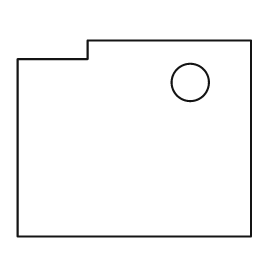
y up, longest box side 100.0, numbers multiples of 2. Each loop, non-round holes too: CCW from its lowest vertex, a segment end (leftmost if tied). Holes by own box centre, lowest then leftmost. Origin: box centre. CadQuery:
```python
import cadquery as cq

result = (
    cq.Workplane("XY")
    .moveTo(-50.0, -42.0)
    .lineTo(50.0, -42.0)
    .lineTo(50.0, 42.0)
    .lineTo(-20.0, 42.0)
    .lineTo(-20.0, 34.0)
    .lineTo(-50.0, 34.0)
    .close()
    .moveTo(24.0, 24.0)
    .circle(8.0)
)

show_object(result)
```